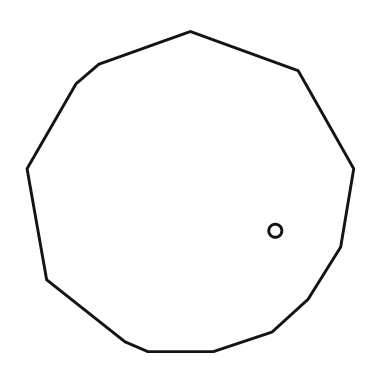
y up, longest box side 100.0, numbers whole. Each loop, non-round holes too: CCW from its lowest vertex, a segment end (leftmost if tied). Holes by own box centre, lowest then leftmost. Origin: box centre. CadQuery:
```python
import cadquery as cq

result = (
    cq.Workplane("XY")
    .moveTo(-13.0, -49.0)
    .lineTo(7.0, -49.0)
    .lineTo(25.0, -43.0)
    .lineTo(36.0, -33.0)
    .lineTo(46.0, -17.0)
    .lineTo(50.0, 7.0)
    .lineTo(33.0, 37.0)
    .lineTo(0.0, 49.0)
    .lineTo(-28.0, 39.0)
    .lineTo(-35.0, 33.0)
    .lineTo(-50.0, 7.0)
    .lineTo(-44.0, -27.0)
    .lineTo(-20.0, -46.0)
    .close()
    .moveTo(26.0, -12.0)
    .circle(2.0)
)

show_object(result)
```